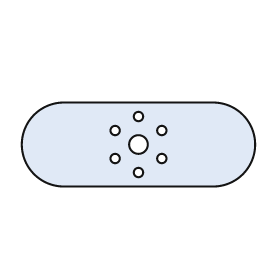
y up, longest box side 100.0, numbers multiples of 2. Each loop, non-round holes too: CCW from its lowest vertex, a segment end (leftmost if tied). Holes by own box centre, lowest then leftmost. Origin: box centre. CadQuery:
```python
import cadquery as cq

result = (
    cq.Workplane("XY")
    .moveTo(-32.0, -18.0)
    .lineTo(32.0, -18.0)
    .threePointArc((50.0, 0.0), (32.0, 18.0))
    .lineTo(-32.0, 18.0)
    .threePointArc((-50.0, 0.0), (-32.0, -18.0))
    .close()
    .moveTo(0.0, -12.0)
    .circle(2.0)
    .moveTo(-10.0, -6.0)
    .circle(2.0)
    .moveTo(10.0, -6.0)
    .circle(2.0)
    .moveTo(0.0, 0.0)
    .circle(4.0)
    .moveTo(-10.0, 6.0)
    .circle(2.0)
    .moveTo(10.0, 6.0)
    .circle(2.0)
    .moveTo(0.0, 12.0)
    .circle(2.0)
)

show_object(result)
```